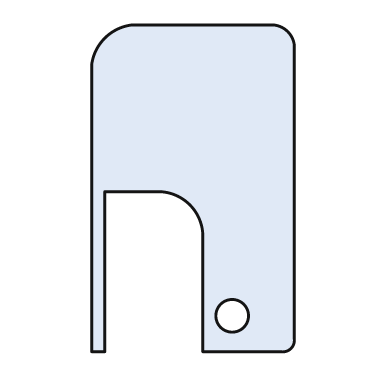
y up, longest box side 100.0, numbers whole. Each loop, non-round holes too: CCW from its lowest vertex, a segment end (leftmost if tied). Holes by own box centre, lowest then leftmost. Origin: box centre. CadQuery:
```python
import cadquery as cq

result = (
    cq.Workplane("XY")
    .moveTo(-31.0, -50.0)
    .lineTo(-27.0, -50.0)
    .lineTo(-27.0, -1.0)
    .lineTo(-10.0, -1.0)
    .threePointArc((-1.0, -5.0), (3.0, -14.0))
    .lineTo(3.0, -50.0)
    .lineTo(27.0, -50.0)
    .threePointArc((30.0, -49.0), (31.0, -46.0))
    .lineTo(31.0, 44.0)
    .threePointArc((29.0, 48.0), (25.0, 50.0))
    .lineTo(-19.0, 50.0)
    .threePointArc((-27.0, 46.0), (-31.0, 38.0))
    .close()
    .moveTo(12.0, -39.0)
    .circle(5.0)
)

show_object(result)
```